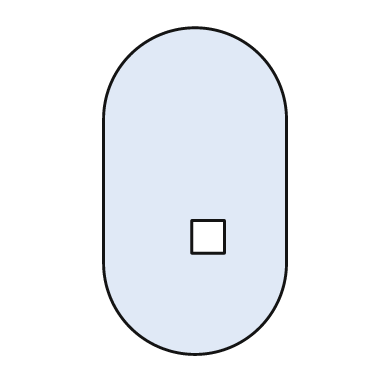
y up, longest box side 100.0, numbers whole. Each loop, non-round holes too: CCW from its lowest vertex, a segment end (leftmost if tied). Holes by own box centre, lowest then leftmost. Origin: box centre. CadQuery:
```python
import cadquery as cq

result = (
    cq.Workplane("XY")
    .moveTo(-28.0, -22.0)
    .threePointArc((0.0, -50.0), (28.0, -22.0))
    .lineTo(28.0, 22.0)
    .threePointArc((0.0, 50.0), (-28.0, 22.0))
    .close()
    .moveTo(-1.0, -19.0)
    .lineTo(9.0, -19.0)
    .lineTo(9.0, -9.0)
    .lineTo(-1.0, -9.0)
    .close()
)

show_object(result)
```